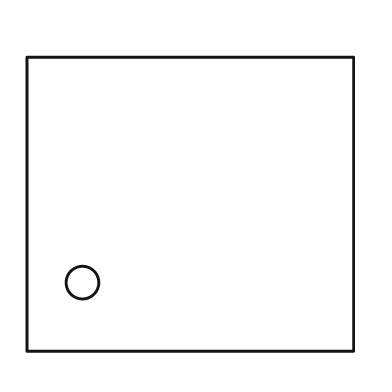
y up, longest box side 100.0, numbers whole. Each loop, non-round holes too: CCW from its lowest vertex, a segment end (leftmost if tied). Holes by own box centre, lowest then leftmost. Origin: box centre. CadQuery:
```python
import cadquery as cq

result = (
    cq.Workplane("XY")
    .moveTo(-50.0, -45.0)
    .lineTo(50.0, -45.0)
    .lineTo(50.0, 45.0)
    .lineTo(-50.0, 45.0)
    .close()
    .moveTo(-33.0, -24.0)
    .circle(5.0)
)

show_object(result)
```